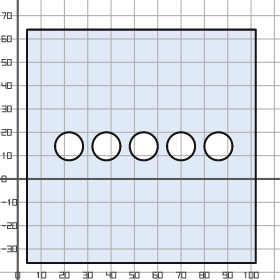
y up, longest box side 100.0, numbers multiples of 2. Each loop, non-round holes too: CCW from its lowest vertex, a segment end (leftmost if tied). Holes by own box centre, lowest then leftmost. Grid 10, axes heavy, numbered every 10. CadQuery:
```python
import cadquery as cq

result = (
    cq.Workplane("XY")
    .moveTo(4.0, -36.0)
    .lineTo(102.0, -36.0)
    .lineTo(102.0, 64.0)
    .lineTo(4.0, 64.0)
    .close()
    .moveTo(22.0, 14.0)
    .circle(6.0)
    .moveTo(38.0, 14.0)
    .circle(6.0)
    .moveTo(54.0, 14.0)
    .circle(6.0)
    .moveTo(70.0, 14.0)
    .circle(6.0)
    .moveTo(86.0, 14.0)
    .circle(6.0)
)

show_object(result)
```